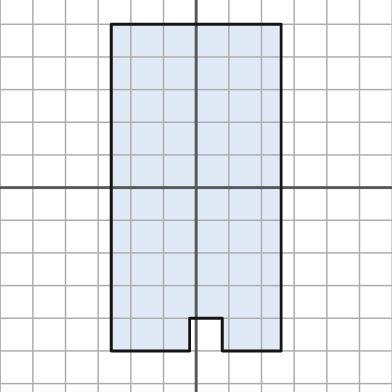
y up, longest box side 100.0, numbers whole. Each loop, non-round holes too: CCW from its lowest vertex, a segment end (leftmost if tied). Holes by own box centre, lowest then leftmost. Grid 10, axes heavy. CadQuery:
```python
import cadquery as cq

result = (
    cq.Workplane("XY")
    .moveTo(-26.0, -50.0)
    .lineTo(-2.0, -50.0)
    .lineTo(-2.0, -40.0)
    .lineTo(8.0, -40.0)
    .lineTo(8.0, -50.0)
    .lineTo(26.0, -50.0)
    .lineTo(26.0, 50.0)
    .lineTo(-26.0, 50.0)
    .close()
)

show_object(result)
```